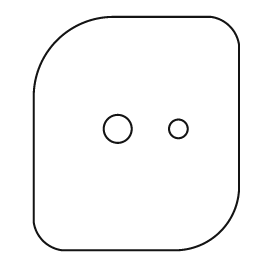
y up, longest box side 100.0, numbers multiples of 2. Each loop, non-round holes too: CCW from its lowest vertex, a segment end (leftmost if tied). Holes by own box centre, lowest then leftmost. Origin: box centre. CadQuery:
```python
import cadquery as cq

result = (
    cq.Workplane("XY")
    .moveTo(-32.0, -50.0)
    .lineTo(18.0, -50.0)
    .threePointArc((36.0, -42.0), (44.0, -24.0))
    .lineTo(44.0, 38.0)
    .threePointArc((40.0, 46.0), (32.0, 50.0))
    .lineTo(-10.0, 50.0)
    .threePointArc((-34.0, 40.0), (-44.0, 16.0))
    .lineTo(-44.0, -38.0)
    .threePointArc((-40.0, -46.0), (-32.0, -50.0))
    .close()
    .moveTo(-8.0, 2.0)
    .circle(6.0)
    .moveTo(18.0, 2.0)
    .circle(4.0)
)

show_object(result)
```